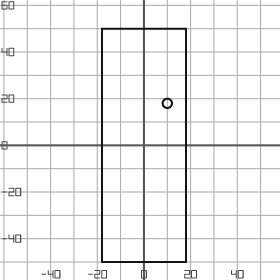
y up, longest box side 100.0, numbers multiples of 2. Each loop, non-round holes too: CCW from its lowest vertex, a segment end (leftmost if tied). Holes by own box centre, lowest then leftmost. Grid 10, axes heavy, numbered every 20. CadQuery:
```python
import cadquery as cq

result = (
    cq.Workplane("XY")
    .moveTo(-18.0, -50.0)
    .lineTo(18.0, -50.0)
    .lineTo(18.0, 50.0)
    .lineTo(-18.0, 50.0)
    .close()
    .moveTo(10.0, 18.0)
    .circle(2.0)
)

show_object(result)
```